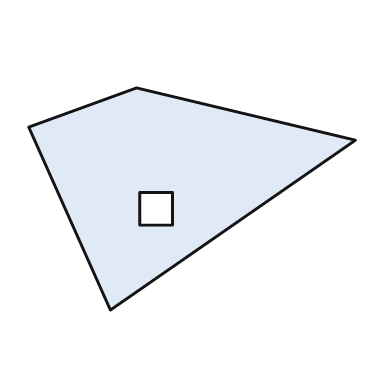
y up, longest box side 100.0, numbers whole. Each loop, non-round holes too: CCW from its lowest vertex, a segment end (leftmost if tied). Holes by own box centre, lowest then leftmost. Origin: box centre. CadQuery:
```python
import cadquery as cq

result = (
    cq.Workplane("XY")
    .moveTo(-25.0, -34.0)
    .lineTo(50.0, 18.0)
    .lineTo(-17.0, 34.0)
    .lineTo(-50.0, 22.0)
    .close()
    .moveTo(-16.0, -8.0)
    .lineTo(-6.0, -8.0)
    .lineTo(-6.0, 2.0)
    .lineTo(-16.0, 2.0)
    .close()
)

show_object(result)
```